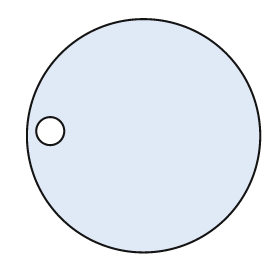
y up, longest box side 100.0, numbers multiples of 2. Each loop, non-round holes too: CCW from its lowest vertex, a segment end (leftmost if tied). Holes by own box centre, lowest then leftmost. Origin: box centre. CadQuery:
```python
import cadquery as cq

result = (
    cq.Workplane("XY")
    .moveTo(0.0, 0.0)
    .circle(50.0)
    .moveTo(-40.0, 2.0)
    .circle(6.0)
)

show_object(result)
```